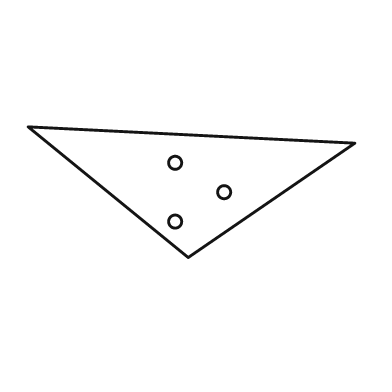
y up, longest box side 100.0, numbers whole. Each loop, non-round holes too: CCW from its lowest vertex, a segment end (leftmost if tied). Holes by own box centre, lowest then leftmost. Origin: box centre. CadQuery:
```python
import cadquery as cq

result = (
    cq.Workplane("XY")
    .moveTo(-1.0, -20.0)
    .lineTo(50.0, 15.0)
    .lineTo(-50.0, 20.0)
    .close()
    .moveTo(-5.0, -9.0)
    .circle(2.0)
    .moveTo(10.0, 0.0)
    .circle(2.0)
    .moveTo(-5.0, 9.0)
    .circle(2.0)
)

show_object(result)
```